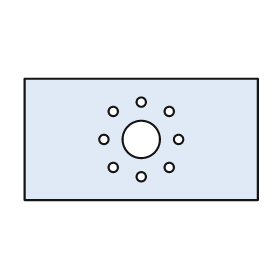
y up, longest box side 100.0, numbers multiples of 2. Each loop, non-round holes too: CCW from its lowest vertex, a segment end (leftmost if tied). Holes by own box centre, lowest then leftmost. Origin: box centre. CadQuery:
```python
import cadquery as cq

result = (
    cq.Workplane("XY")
    .moveTo(-50.0, -26.0)
    .lineTo(50.0, -26.0)
    .lineTo(50.0, 26.0)
    .lineTo(-50.0, 26.0)
    .close()
    .moveTo(0.0, -16.0)
    .circle(2.0)
    .moveTo(-12.0, -12.0)
    .circle(2.0)
    .moveTo(12.0, -12.0)
    .circle(2.0)
    .moveTo(-16.0, 0.0)
    .circle(2.0)
    .moveTo(0.0, 0.0)
    .circle(8.0)
    .moveTo(16.0, 0.0)
    .circle(2.0)
    .moveTo(-12.0, 12.0)
    .circle(2.0)
    .moveTo(12.0, 12.0)
    .circle(2.0)
    .moveTo(0.0, 16.0)
    .circle(2.0)
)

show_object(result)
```